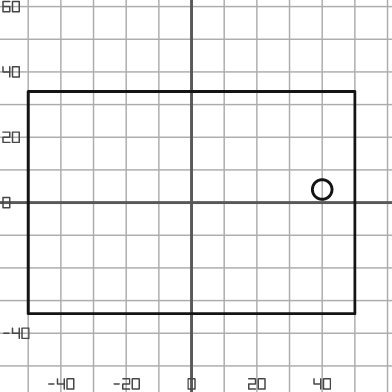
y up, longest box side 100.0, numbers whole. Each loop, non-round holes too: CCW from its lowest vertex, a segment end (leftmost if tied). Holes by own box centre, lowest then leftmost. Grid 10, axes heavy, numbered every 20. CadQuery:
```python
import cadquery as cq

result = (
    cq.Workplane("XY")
    .moveTo(-50.0, -34.0)
    .lineTo(50.0, -34.0)
    .lineTo(50.0, 34.0)
    .lineTo(-50.0, 34.0)
    .close()
    .moveTo(40.0, 4.0)
    .circle(3.0)
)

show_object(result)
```